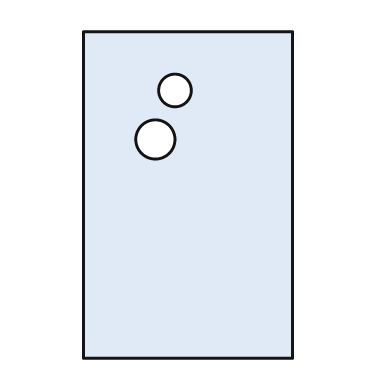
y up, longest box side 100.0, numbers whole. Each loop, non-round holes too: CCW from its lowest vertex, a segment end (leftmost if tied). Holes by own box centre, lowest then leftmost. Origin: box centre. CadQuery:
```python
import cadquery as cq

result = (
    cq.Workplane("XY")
    .moveTo(-32.0, -50.0)
    .lineTo(32.0, -50.0)
    .lineTo(32.0, 50.0)
    .lineTo(-32.0, 50.0)
    .close()
    .moveTo(-10.0, 17.0)
    .circle(6.0)
    .moveTo(-4.0, 32.0)
    .circle(5.0)
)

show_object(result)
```